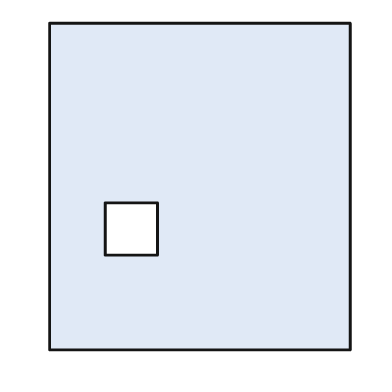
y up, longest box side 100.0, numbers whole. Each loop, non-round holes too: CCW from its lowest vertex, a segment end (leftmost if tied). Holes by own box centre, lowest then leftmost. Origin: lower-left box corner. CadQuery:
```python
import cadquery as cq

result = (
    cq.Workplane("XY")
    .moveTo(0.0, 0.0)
    .lineTo(92.0, 0.0)
    .lineTo(92.0, 100.0)
    .lineTo(0.0, 100.0)
    .close()
    .moveTo(17.0, 29.0)
    .lineTo(33.0, 29.0)
    .lineTo(33.0, 45.0)
    .lineTo(17.0, 45.0)
    .close()
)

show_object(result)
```